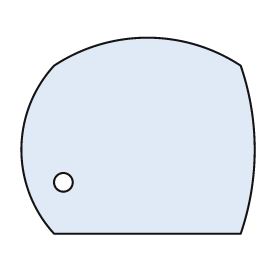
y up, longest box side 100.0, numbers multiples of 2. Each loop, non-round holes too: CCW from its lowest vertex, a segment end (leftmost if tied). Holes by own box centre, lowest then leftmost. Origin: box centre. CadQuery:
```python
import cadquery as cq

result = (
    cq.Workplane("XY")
    .moveTo(-36.0, -42.0)
    .lineTo(44.0, -42.0)
    .threePointArc((50.0, -6.0), (44.0, 30.0))
    .threePointArc((4.0, 42.0), (-36.0, 30.0))
    .threePointArc((-50.0, -6.0), (-36.0, -42.0))
    .close()
    .moveTo(-32.0, -20.0)
    .circle(4.0)
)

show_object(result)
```